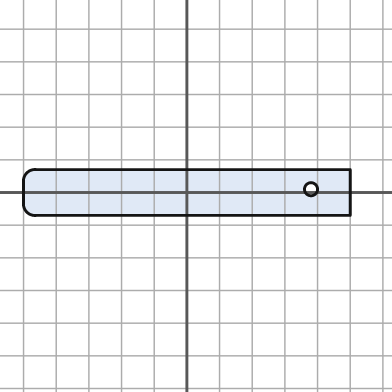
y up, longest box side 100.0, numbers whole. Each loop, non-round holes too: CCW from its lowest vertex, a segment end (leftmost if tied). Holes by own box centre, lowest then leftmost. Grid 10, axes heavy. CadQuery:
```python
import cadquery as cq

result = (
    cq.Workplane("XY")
    .moveTo(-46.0, -7.0)
    .lineTo(50.0, -7.0)
    .lineTo(50.0, 7.0)
    .lineTo(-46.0, 7.0)
    .threePointArc((-49.0, 6.0), (-50.0, 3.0))
    .lineTo(-50.0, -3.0)
    .threePointArc((-49.0, -6.0), (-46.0, -7.0))
    .close()
    .moveTo(38.0, 1.0)
    .circle(2.0)
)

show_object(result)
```